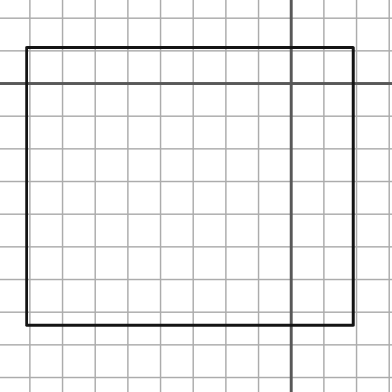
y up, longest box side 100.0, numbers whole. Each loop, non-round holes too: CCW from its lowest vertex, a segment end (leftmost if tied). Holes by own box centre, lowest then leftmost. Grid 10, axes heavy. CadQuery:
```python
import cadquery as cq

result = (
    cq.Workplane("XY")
    .moveTo(-81.0, -74.0)
    .lineTo(19.0, -74.0)
    .lineTo(19.0, 11.0)
    .lineTo(-81.0, 11.0)
    .close()
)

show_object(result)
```